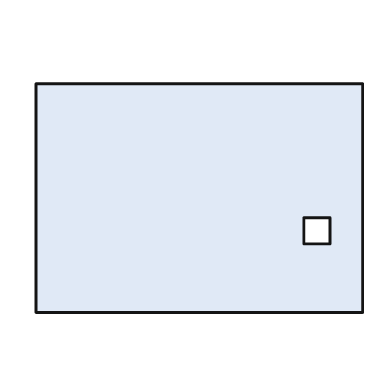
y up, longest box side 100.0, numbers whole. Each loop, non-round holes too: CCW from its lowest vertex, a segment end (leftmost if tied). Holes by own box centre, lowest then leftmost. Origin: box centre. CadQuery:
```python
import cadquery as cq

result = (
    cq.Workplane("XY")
    .moveTo(-50.0, -35.0)
    .lineTo(50.0, -35.0)
    .lineTo(50.0, 35.0)
    .lineTo(-50.0, 35.0)
    .close()
    .moveTo(32.0, -14.0)
    .lineTo(40.0, -14.0)
    .lineTo(40.0, -6.0)
    .lineTo(32.0, -6.0)
    .close()
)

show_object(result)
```